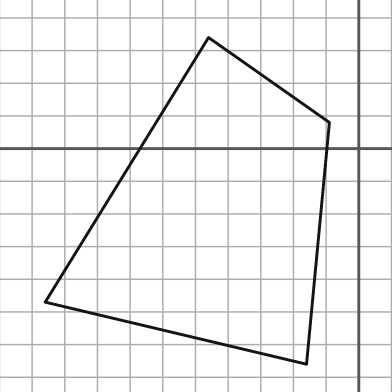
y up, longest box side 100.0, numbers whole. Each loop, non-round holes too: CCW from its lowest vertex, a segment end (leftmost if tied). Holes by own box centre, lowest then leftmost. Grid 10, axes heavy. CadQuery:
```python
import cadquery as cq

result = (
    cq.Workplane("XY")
    .moveTo(-16.0, -66.0)
    .lineTo(-9.0, 8.0)
    .lineTo(-46.0, 34.0)
    .lineTo(-96.0, -47.0)
    .close()
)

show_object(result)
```